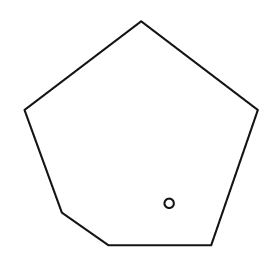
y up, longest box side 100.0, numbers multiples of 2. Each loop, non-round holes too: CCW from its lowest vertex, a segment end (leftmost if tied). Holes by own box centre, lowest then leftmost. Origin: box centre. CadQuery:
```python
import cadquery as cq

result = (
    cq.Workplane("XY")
    .moveTo(-14.0, -48.0)
    .lineTo(30.0, -48.0)
    .lineTo(50.0, 10.0)
    .lineTo(0.0, 48.0)
    .lineTo(-50.0, 10.0)
    .lineTo(-34.0, -34.0)
    .close()
    .moveTo(12.0, -30.0)
    .circle(2.0)
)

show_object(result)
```